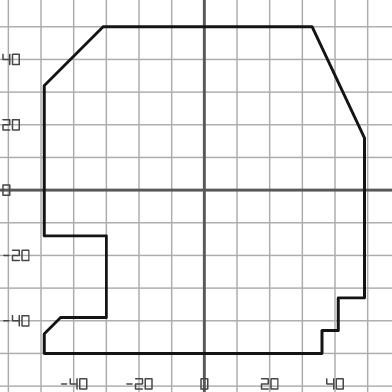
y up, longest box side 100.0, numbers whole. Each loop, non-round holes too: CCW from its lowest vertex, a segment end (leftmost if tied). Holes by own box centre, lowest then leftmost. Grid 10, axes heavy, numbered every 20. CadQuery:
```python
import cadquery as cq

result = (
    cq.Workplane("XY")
    .moveTo(-49.0, -50.0)
    .lineTo(36.0, -50.0)
    .lineTo(36.0, -43.0)
    .lineTo(41.0, -43.0)
    .lineTo(41.0, -33.0)
    .lineTo(49.0, -33.0)
    .lineTo(49.0, 16.0)
    .lineTo(33.0, 50.0)
    .lineTo(-31.0, 50.0)
    .lineTo(-49.0, 32.0)
    .lineTo(-49.0, -14.0)
    .lineTo(-30.0, -14.0)
    .lineTo(-30.0, -39.0)
    .lineTo(-44.0, -39.0)
    .lineTo(-49.0, -44.0)
    .close()
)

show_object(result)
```